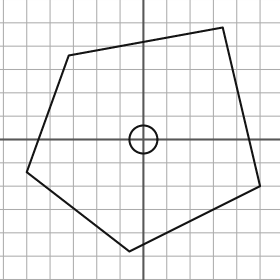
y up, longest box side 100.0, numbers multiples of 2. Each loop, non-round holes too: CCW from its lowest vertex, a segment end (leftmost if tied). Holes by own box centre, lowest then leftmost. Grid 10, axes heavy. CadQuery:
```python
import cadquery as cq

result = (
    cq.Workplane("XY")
    .moveTo(-6.0, -48.0)
    .lineTo(50.0, -20.0)
    .lineTo(34.0, 48.0)
    .lineTo(-32.0, 36.0)
    .lineTo(-50.0, -14.0)
    .close()
    .moveTo(0.0, 0.0)
    .circle(6.0)
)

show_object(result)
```